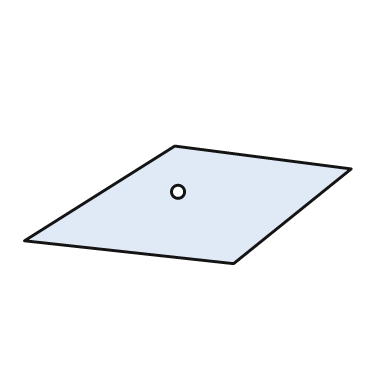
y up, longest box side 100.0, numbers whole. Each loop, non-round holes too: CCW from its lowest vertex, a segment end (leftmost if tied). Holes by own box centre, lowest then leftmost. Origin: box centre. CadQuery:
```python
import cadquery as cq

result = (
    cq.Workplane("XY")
    .moveTo(14.0, -18.0)
    .lineTo(50.0, 11.0)
    .lineTo(-4.0, 18.0)
    .lineTo(-50.0, -11.0)
    .close()
    .moveTo(-3.0, 4.0)
    .circle(2.0)
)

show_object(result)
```